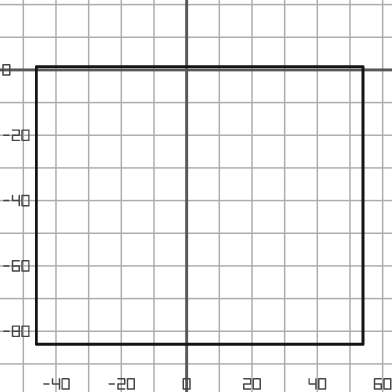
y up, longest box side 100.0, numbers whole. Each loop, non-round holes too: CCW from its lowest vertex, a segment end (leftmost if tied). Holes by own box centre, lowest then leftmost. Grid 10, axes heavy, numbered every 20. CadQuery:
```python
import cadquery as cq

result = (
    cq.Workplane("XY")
    .moveTo(-46.0, -84.0)
    .lineTo(54.0, -84.0)
    .lineTo(54.0, 1.0)
    .lineTo(-46.0, 1.0)
    .close()
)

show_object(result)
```